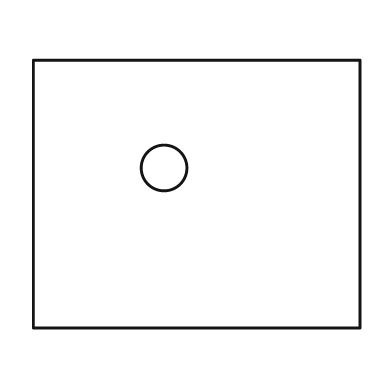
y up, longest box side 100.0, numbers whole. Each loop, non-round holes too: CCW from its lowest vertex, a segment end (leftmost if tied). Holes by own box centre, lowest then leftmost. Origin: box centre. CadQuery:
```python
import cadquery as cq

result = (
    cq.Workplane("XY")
    .moveTo(-50.0, -41.0)
    .lineTo(50.0, -41.0)
    .lineTo(50.0, 41.0)
    .lineTo(-50.0, 41.0)
    .close()
    .moveTo(-10.0, 8.0)
    .circle(7.0)
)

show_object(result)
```